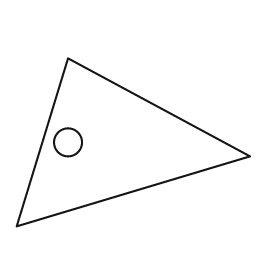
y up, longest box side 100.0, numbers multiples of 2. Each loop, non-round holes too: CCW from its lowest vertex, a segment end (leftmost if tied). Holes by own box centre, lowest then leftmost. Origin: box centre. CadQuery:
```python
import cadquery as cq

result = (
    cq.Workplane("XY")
    .moveTo(-50.0, -36.0)
    .lineTo(50.0, -6.0)
    .lineTo(-28.0, 36.0)
    .close()
    .moveTo(-28.0, 0.0)
    .circle(6.0)
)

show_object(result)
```